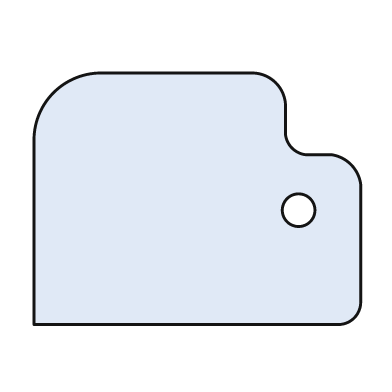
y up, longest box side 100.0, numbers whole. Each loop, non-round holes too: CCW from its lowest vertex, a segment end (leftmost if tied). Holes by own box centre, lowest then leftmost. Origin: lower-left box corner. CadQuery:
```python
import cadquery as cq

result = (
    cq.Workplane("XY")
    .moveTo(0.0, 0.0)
    .lineTo(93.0, 0.0)
    .threePointArc((98.0, 2.0), (100.0, 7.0))
    .lineTo(100.0, 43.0)
    .threePointArc((97.0, 49.0), (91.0, 52.0))
    .lineTo(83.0, 52.0)
    .threePointArc((79.0, 54.0), (77.0, 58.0))
    .lineTo(77.0, 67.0)
    .threePointArc((74.0, 74.0), (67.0, 77.0))
    .lineTo(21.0, 77.0)
    .threePointArc((6.0, 71.0), (0.0, 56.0))
    .close()
    .moveTo(81.0, 35.0)
    .circle(5.0)
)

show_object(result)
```